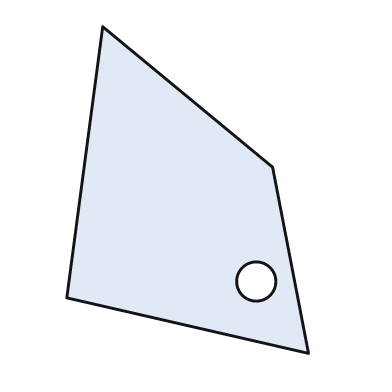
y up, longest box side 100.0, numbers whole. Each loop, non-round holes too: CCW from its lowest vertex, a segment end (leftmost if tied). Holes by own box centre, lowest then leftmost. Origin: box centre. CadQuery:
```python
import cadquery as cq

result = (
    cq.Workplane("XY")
    .moveTo(37.0, -50.0)
    .lineTo(26.0, 7.0)
    .lineTo(-26.0, 50.0)
    .lineTo(-37.0, -33.0)
    .close()
    .moveTo(21.0, -28.0)
    .circle(6.0)
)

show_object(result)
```